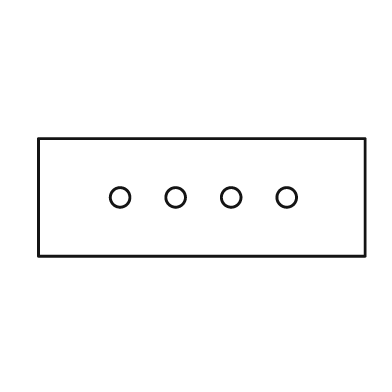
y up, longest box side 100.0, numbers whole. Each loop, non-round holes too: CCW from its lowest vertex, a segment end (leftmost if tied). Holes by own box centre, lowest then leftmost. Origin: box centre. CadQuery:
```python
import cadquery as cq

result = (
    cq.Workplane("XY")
    .moveTo(-50.0, -18.0)
    .lineTo(50.0, -18.0)
    .lineTo(50.0, 18.0)
    .lineTo(-50.0, 18.0)
    .close()
    .moveTo(-25.0, 0.0)
    .circle(3.0)
    .moveTo(-8.0, 0.0)
    .circle(3.0)
    .moveTo(9.0, 0.0)
    .circle(3.0)
    .moveTo(26.0, 0.0)
    .circle(3.0)
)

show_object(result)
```